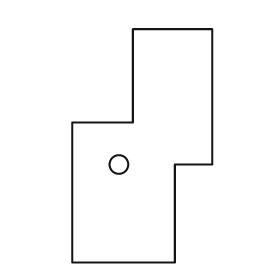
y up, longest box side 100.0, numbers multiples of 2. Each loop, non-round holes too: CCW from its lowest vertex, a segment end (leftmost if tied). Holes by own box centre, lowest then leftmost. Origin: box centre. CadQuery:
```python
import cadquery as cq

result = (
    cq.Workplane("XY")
    .moveTo(-30.0, -50.0)
    .lineTo(14.0, -50.0)
    .lineTo(14.0, -8.0)
    .lineTo(30.0, -8.0)
    .lineTo(30.0, 50.0)
    .lineTo(-4.0, 50.0)
    .lineTo(-4.0, 10.0)
    .lineTo(-30.0, 10.0)
    .close()
    .moveTo(-10.0, -8.0)
    .circle(4.0)
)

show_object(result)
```